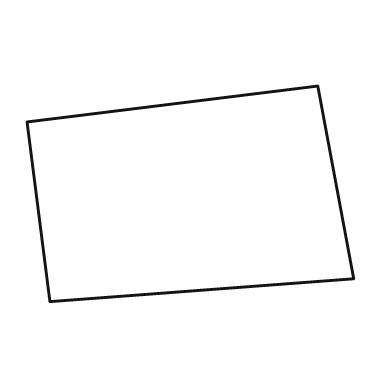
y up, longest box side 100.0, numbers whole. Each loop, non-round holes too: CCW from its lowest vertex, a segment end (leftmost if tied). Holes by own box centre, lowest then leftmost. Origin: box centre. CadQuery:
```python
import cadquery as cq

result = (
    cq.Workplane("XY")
    .moveTo(-43.0, -33.0)
    .lineTo(50.0, -26.0)
    .lineTo(39.0, 33.0)
    .lineTo(-50.0, 22.0)
    .close()
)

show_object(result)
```